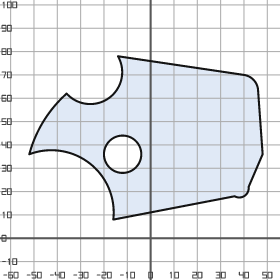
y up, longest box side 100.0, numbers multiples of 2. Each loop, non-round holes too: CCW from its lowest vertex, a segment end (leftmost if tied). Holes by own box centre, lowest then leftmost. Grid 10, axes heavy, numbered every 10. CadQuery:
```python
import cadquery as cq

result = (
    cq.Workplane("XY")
    .moveTo(-16.0, 8.0)
    .lineTo(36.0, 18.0)
    .threePointArc((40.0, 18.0), (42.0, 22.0))
    .lineTo(48.0, 36.0)
    .lineTo(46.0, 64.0)
    .threePointArc((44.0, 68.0), (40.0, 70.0))
    .lineTo(-14.0, 78.0)
    .threePointArc((-18.0, 60.0), (-36.0, 62.0))
    .threePointArc((-46.0, 50.0), (-52.0, 36.0))
    .threePointArc((-26.0, 32.0), (-16.0, 8.0))
    .close()
    .moveTo(-12.0, 36.0)
    .circle(8.0)
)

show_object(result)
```